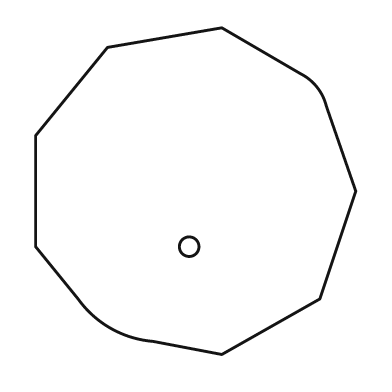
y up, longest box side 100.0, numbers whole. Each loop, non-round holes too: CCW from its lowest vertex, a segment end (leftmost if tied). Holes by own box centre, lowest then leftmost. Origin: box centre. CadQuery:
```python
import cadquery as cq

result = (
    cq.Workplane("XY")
    .moveTo(8.0, -50.0)
    .lineTo(38.0, -33.0)
    .lineTo(49.0, 0.0)
    .lineTo(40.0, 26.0)
    .threePointArc((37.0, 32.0), (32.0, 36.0))
    .lineTo(8.0, 50.0)
    .lineTo(-27.0, 44.0)
    .lineTo(-49.0, 17.0)
    .lineTo(-49.0, -17.0)
    .lineTo(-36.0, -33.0)
    .threePointArc((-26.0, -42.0), (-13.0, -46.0))
    .close()
    .moveTo(-2.0, -17.0)
    .circle(3.0)
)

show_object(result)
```